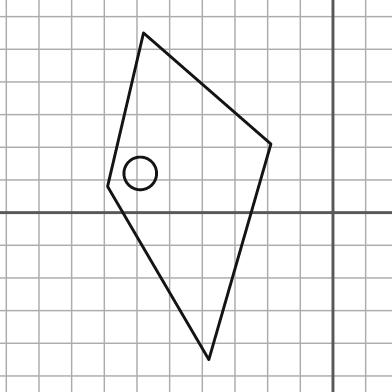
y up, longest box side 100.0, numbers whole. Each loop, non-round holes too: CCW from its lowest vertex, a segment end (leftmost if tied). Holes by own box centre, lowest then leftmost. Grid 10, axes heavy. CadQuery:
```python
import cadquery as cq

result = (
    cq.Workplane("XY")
    .moveTo(-38.0, -45.0)
    .lineTo(-19.0, 21.0)
    .lineTo(-58.0, 55.0)
    .lineTo(-69.0, 8.0)
    .close()
    .moveTo(-59.0, 12.0)
    .circle(5.0)
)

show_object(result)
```